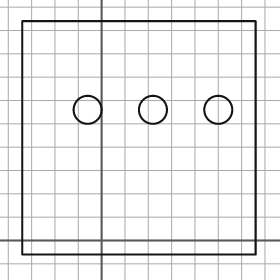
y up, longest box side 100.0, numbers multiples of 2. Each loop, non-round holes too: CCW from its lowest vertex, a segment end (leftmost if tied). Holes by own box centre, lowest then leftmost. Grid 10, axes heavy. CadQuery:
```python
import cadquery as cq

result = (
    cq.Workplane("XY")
    .moveTo(-34.0, -6.0)
    .lineTo(66.0, -6.0)
    .lineTo(66.0, 94.0)
    .lineTo(-34.0, 94.0)
    .close()
    .moveTo(-6.0, 56.0)
    .circle(6.0)
    .moveTo(22.0, 56.0)
    .circle(6.0)
    .moveTo(50.0, 56.0)
    .circle(6.0)
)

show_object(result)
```